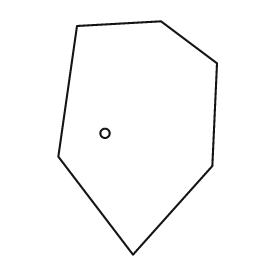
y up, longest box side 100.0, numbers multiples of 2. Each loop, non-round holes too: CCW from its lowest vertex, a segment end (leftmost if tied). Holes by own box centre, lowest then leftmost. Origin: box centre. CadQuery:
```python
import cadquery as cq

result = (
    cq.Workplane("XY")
    .moveTo(-2.0, -50.0)
    .lineTo(32.0, -12.0)
    .lineTo(34.0, 32.0)
    .lineTo(10.0, 50.0)
    .lineTo(-26.0, 48.0)
    .lineTo(-34.0, -8.0)
    .close()
    .moveTo(-14.0, 2.0)
    .circle(2.0)
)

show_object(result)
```